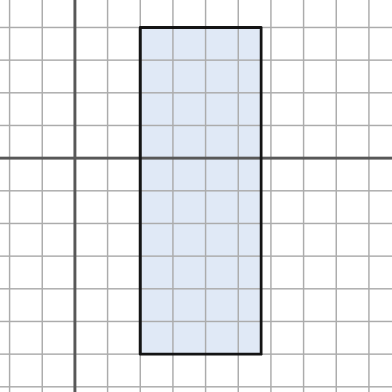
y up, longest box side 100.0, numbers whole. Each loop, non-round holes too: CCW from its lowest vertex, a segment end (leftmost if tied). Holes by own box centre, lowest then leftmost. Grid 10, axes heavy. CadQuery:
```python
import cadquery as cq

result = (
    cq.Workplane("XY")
    .moveTo(20.0, -60.0)
    .lineTo(57.0, -60.0)
    .lineTo(57.0, 40.0)
    .lineTo(20.0, 40.0)
    .close()
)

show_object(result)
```